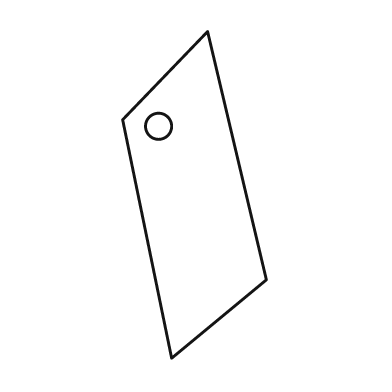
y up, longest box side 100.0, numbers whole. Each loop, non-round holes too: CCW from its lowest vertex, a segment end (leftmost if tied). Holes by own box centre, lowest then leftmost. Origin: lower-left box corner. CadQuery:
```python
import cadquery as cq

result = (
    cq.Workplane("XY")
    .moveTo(15.0, 0.0)
    .lineTo(44.0, 24.0)
    .lineTo(26.0, 100.0)
    .lineTo(0.0, 73.0)
    .close()
    .moveTo(11.0, 71.0)
    .circle(4.0)
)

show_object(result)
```